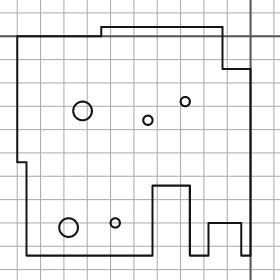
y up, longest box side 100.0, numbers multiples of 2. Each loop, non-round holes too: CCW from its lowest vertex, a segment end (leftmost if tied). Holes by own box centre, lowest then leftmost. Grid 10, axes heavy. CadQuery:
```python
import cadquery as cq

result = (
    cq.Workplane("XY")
    .moveTo(-96.0, -94.0)
    .lineTo(-42.0, -94.0)
    .lineTo(-42.0, -64.0)
    .lineTo(-26.0, -64.0)
    .lineTo(-26.0, -94.0)
    .lineTo(-18.0, -94.0)
    .lineTo(-18.0, -80.0)
    .lineTo(-4.0, -80.0)
    .lineTo(-4.0, -94.0)
    .lineTo(0.0, -94.0)
    .lineTo(0.0, -14.0)
    .lineTo(-12.0, -14.0)
    .lineTo(-12.0, 4.0)
    .lineTo(-64.0, 4.0)
    .lineTo(-64.0, 0.0)
    .lineTo(-100.0, 0.0)
    .lineTo(-100.0, -54.0)
    .lineTo(-96.0, -54.0)
    .close()
    .moveTo(-78.0, -82.0)
    .circle(4.0)
    .moveTo(-58.0, -80.0)
    .circle(2.0)
    .moveTo(-44.0, -36.0)
    .circle(2.0)
    .moveTo(-72.0, -32.0)
    .circle(4.0)
    .moveTo(-28.0, -28.0)
    .circle(2.0)
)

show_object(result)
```